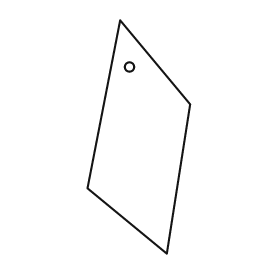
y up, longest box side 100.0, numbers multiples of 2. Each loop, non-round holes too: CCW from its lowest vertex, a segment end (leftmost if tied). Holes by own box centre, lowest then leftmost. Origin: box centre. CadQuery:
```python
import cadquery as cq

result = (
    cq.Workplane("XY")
    .moveTo(12.0, -50.0)
    .lineTo(22.0, 14.0)
    .lineTo(-8.0, 50.0)
    .lineTo(-22.0, -22.0)
    .close()
    .moveTo(-4.0, 30.0)
    .circle(2.0)
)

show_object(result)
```